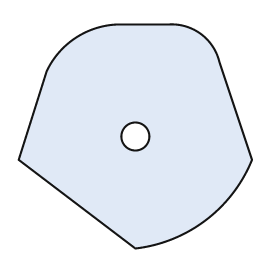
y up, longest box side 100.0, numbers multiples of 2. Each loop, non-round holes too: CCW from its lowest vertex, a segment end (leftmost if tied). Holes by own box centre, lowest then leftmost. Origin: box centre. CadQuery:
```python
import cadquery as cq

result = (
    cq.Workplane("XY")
    .moveTo(0.0, -48.0)
    .threePointArc((30.0, -36.0), (50.0, -10.0))
    .lineTo(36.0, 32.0)
    .threePointArc((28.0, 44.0), (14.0, 48.0))
    .lineTo(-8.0, 48.0)
    .threePointArc((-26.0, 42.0), (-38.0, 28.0))
    .lineTo(-50.0, -10.0)
    .close()
    .moveTo(0.0, 0.0)
    .circle(6.0)
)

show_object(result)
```